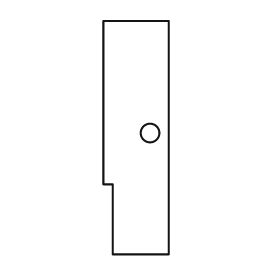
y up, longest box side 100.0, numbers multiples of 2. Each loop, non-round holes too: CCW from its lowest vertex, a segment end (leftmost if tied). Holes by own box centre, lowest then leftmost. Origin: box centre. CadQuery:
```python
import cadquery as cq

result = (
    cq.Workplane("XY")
    .moveTo(-10.0, -50.0)
    .lineTo(14.0, -50.0)
    .lineTo(14.0, 50.0)
    .lineTo(-14.0, 50.0)
    .lineTo(-14.0, -20.0)
    .lineTo(-10.0, -20.0)
    .close()
    .moveTo(6.0, 2.0)
    .circle(4.0)
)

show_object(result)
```